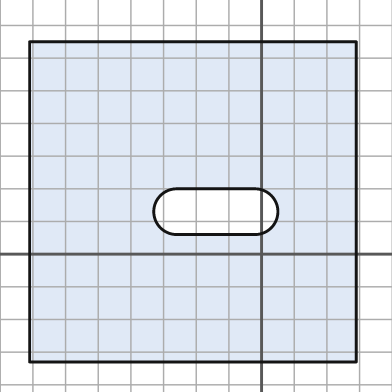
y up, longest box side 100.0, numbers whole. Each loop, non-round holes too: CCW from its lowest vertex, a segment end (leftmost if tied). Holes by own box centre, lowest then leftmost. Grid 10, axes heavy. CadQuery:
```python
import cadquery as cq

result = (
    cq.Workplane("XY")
    .moveTo(-71.0, -33.0)
    .lineTo(29.0, -33.0)
    .lineTo(29.0, 65.0)
    .lineTo(-71.0, 65.0)
    .close()
    .moveTo(-26.0, 6.0)
    .lineTo(-2.0, 6.0)
    .threePointArc((5.0, 13.0), (-2.0, 20.0))
    .lineTo(-26.0, 20.0)
    .threePointArc((-33.0, 13.0), (-26.0, 6.0))
    .close()
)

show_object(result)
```